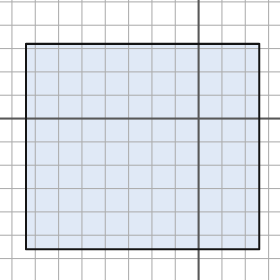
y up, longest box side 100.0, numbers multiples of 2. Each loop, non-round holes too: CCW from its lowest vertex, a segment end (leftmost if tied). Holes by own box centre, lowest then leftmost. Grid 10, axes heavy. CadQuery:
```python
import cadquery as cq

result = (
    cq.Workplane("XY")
    .moveTo(-74.0, -56.0)
    .lineTo(26.0, -56.0)
    .lineTo(26.0, 32.0)
    .lineTo(-74.0, 32.0)
    .close()
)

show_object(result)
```